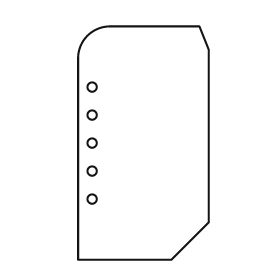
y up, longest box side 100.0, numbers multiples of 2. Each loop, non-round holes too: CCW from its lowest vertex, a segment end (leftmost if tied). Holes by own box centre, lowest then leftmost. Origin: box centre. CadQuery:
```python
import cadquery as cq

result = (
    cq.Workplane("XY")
    .moveTo(-28.0, -50.0)
    .lineTo(12.0, -50.0)
    .lineTo(28.0, -34.0)
    .lineTo(28.0, 40.0)
    .lineTo(24.0, 50.0)
    .lineTo(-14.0, 50.0)
    .threePointArc((-24.0, 46.0), (-28.0, 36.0))
    .close()
    .moveTo(-22.0, -24.0)
    .circle(2.0)
    .moveTo(-22.0, -12.0)
    .circle(2.0)
    .moveTo(-22.0, 0.0)
    .circle(2.0)
    .moveTo(-22.0, 12.0)
    .circle(2.0)
    .moveTo(-22.0, 24.0)
    .circle(2.0)
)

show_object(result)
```